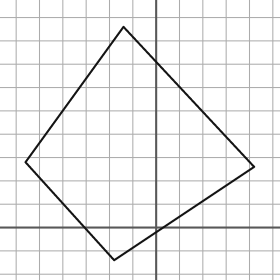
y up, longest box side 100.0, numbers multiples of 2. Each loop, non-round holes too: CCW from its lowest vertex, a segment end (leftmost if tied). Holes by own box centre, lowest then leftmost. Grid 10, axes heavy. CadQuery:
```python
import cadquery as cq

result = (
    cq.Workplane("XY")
    .moveTo(-18.0, -14.0)
    .lineTo(42.0, 26.0)
    .lineTo(-14.0, 86.0)
    .lineTo(-56.0, 28.0)
    .close()
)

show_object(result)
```